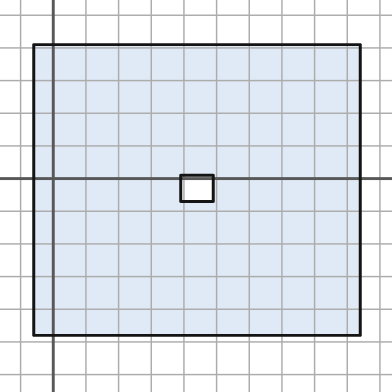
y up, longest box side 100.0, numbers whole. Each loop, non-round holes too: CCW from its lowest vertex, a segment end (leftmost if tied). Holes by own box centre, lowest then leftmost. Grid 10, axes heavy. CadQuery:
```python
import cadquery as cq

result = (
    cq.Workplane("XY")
    .moveTo(-6.0, -48.0)
    .lineTo(94.0, -48.0)
    .lineTo(94.0, 41.0)
    .lineTo(-6.0, 41.0)
    .close()
    .moveTo(39.0, -7.0)
    .lineTo(49.0, -7.0)
    .lineTo(49.0, 1.0)
    .lineTo(39.0, 1.0)
    .close()
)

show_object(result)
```